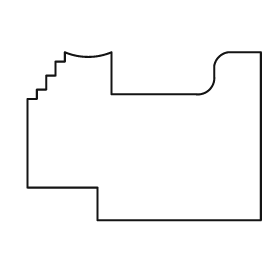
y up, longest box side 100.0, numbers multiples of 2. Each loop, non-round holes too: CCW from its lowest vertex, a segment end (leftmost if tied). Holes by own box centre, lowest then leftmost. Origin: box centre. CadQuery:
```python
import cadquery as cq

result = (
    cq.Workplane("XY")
    .moveTo(-20.0, -36.0)
    .lineTo(50.0, -36.0)
    .lineTo(50.0, 36.0)
    .lineTo(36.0, 36.0)
    .threePointArc((32.0, 34.0), (30.0, 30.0))
    .lineTo(30.0, 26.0)
    .threePointArc((28.0, 20.0), (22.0, 18.0))
    .lineTo(-14.0, 18.0)
    .lineTo(-14.0, 36.0)
    .threePointArc((-24.0, 34.0), (-34.0, 36.0))
    .lineTo(-34.0, 32.0)
    .lineTo(-38.0, 32.0)
    .lineTo(-38.0, 26.0)
    .lineTo(-42.0, 26.0)
    .lineTo(-42.0, 20.0)
    .lineTo(-46.0, 20.0)
    .lineTo(-46.0, 16.0)
    .lineTo(-50.0, 16.0)
    .lineTo(-50.0, -22.0)
    .lineTo(-20.0, -22.0)
    .close()
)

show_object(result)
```